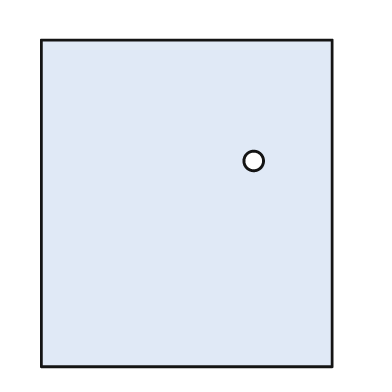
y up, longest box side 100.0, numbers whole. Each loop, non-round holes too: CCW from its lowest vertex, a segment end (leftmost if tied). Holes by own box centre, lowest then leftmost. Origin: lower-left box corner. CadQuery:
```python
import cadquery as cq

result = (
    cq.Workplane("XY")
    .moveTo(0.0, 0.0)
    .lineTo(89.0, 0.0)
    .lineTo(89.0, 100.0)
    .lineTo(0.0, 100.0)
    .close()
    .moveTo(65.0, 63.0)
    .circle(3.0)
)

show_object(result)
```